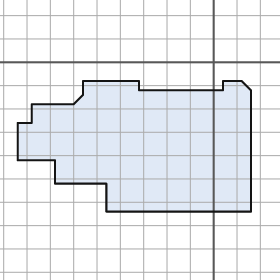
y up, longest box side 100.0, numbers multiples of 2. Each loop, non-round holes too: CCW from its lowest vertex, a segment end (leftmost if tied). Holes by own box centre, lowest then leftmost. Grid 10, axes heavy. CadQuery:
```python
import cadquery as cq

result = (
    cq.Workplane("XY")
    .moveTo(-46.0, -64.0)
    .lineTo(16.0, -64.0)
    .lineTo(16.0, -12.0)
    .lineTo(12.0, -8.0)
    .lineTo(4.0, -8.0)
    .lineTo(4.0, -12.0)
    .lineTo(-32.0, -12.0)
    .lineTo(-32.0, -8.0)
    .lineTo(-56.0, -8.0)
    .lineTo(-56.0, -14.0)
    .lineTo(-60.0, -18.0)
    .lineTo(-78.0, -18.0)
    .lineTo(-78.0, -26.0)
    .lineTo(-84.0, -26.0)
    .lineTo(-84.0, -42.0)
    .lineTo(-68.0, -42.0)
    .lineTo(-68.0, -52.0)
    .lineTo(-46.0, -52.0)
    .close()
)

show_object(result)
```